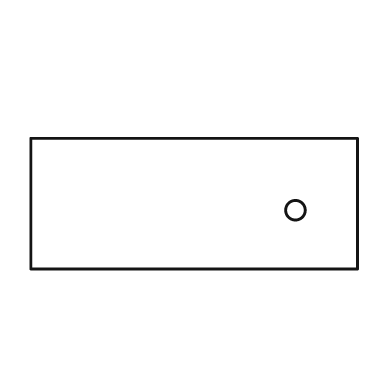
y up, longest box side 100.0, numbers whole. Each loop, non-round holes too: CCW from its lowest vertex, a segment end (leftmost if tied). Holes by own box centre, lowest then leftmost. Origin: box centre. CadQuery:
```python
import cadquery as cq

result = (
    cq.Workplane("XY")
    .moveTo(-50.0, -20.0)
    .lineTo(50.0, -20.0)
    .lineTo(50.0, 20.0)
    .lineTo(-50.0, 20.0)
    .close()
    .moveTo(31.0, -2.0)
    .circle(3.0)
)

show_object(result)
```